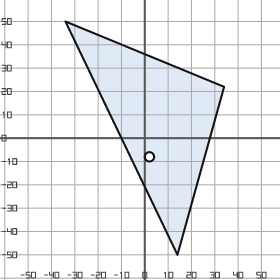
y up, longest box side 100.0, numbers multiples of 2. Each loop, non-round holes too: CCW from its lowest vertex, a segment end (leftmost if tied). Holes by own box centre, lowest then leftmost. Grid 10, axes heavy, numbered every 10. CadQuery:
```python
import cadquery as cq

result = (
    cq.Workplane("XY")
    .moveTo(14.0, -50.0)
    .lineTo(34.0, 22.0)
    .lineTo(-34.0, 50.0)
    .close()
    .moveTo(2.0, -8.0)
    .circle(2.0)
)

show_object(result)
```